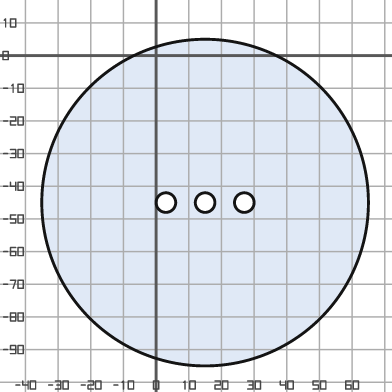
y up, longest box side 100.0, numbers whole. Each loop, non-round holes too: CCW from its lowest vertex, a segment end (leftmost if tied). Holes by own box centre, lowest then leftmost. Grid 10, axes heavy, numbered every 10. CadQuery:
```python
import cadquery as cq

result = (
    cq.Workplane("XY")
    .moveTo(15.0, -45.0)
    .circle(50.0)
    .moveTo(3.0, -45.0)
    .circle(3.0)
    .moveTo(15.0, -45.0)
    .circle(3.0)
    .moveTo(27.0, -45.0)
    .circle(3.0)
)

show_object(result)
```